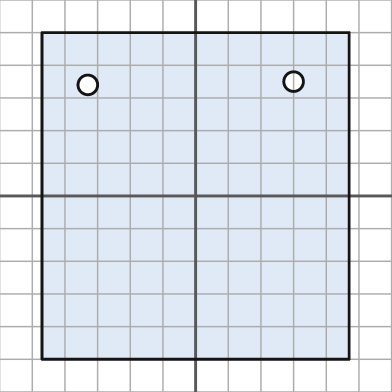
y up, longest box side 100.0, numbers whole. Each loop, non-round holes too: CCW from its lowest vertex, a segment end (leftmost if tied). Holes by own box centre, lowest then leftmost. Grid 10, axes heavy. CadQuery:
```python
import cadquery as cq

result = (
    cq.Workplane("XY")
    .moveTo(-47.0, -50.0)
    .lineTo(47.0, -50.0)
    .lineTo(47.0, 50.0)
    .lineTo(-47.0, 50.0)
    .close()
    .moveTo(-33.0, 34.0)
    .circle(3.0)
    .moveTo(30.0, 35.0)
    .circle(3.0)
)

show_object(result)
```